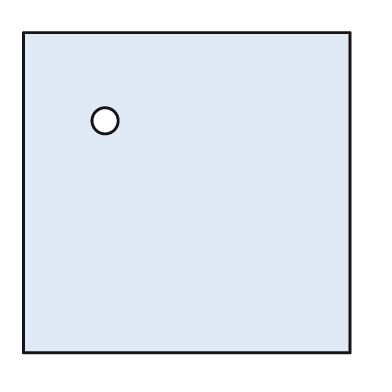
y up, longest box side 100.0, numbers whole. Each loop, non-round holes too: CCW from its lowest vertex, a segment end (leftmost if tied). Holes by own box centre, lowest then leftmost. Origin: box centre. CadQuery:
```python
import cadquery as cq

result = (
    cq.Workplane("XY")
    .moveTo(-50.0, -49.0)
    .lineTo(50.0, -49.0)
    .lineTo(50.0, 49.0)
    .lineTo(-50.0, 49.0)
    .close()
    .moveTo(-25.0, 22.0)
    .circle(4.0)
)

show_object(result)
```